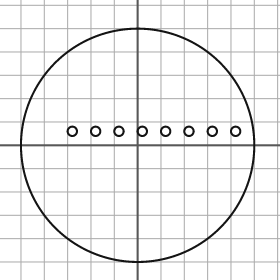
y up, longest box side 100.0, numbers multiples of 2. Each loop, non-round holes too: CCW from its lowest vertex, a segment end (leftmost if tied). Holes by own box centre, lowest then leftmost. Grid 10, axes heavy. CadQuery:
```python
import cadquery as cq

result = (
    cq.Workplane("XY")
    .moveTo(0.0, 0.0)
    .circle(50.0)
    .moveTo(-28.0, 6.0)
    .circle(2.0)
    .moveTo(-18.0, 6.0)
    .circle(2.0)
    .moveTo(-8.0, 6.0)
    .circle(2.0)
    .moveTo(2.0, 6.0)
    .circle(2.0)
    .moveTo(12.0, 6.0)
    .circle(2.0)
    .moveTo(22.0, 6.0)
    .circle(2.0)
    .moveTo(32.0, 6.0)
    .circle(2.0)
    .moveTo(42.0, 6.0)
    .circle(2.0)
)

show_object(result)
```